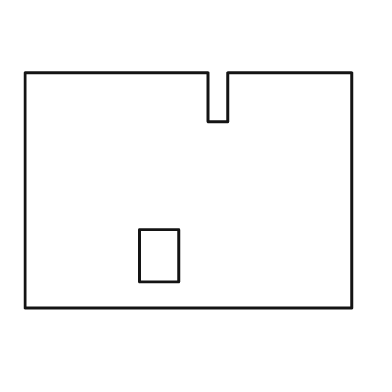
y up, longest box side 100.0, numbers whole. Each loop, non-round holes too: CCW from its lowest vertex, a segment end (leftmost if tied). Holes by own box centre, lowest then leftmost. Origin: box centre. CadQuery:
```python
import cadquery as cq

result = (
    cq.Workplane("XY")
    .moveTo(-50.0, -36.0)
    .lineTo(50.0, -36.0)
    .lineTo(50.0, 36.0)
    .lineTo(12.0, 36.0)
    .lineTo(12.0, 21.0)
    .lineTo(6.0, 21.0)
    .lineTo(6.0, 36.0)
    .lineTo(-50.0, 36.0)
    .close()
    .moveTo(-15.0, -28.0)
    .lineTo(-3.0, -28.0)
    .lineTo(-3.0, -12.0)
    .lineTo(-15.0, -12.0)
    .close()
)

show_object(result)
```